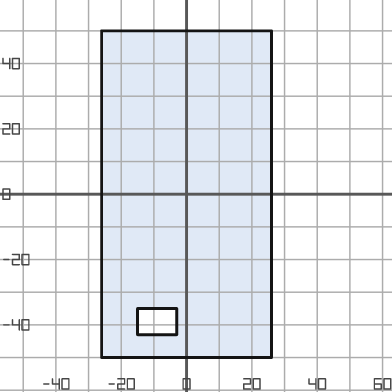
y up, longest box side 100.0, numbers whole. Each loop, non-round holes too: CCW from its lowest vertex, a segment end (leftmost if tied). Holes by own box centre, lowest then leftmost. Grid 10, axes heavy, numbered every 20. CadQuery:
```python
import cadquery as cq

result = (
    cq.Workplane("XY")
    .moveTo(-26.0, -50.0)
    .lineTo(26.0, -50.0)
    .lineTo(26.0, 50.0)
    .lineTo(-26.0, 50.0)
    .close()
    .moveTo(-15.0, -43.0)
    .lineTo(-3.0, -43.0)
    .lineTo(-3.0, -35.0)
    .lineTo(-15.0, -35.0)
    .close()
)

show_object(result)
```